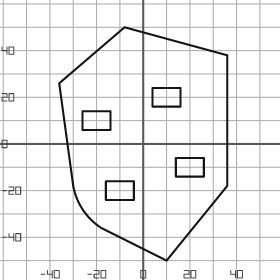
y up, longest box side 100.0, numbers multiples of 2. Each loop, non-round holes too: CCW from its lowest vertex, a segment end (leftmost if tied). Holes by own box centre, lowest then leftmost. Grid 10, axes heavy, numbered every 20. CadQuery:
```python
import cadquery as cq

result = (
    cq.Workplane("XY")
    .moveTo(10.0, -50.0)
    .lineTo(36.0, -18.0)
    .lineTo(36.0, 38.0)
    .lineTo(-8.0, 50.0)
    .lineTo(-36.0, 26.0)
    .lineTo(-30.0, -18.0)
    .threePointArc((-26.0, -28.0), (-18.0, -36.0))
    .close()
    .moveTo(-16.0, -24.0)
    .lineTo(-4.0, -24.0)
    .lineTo(-4.0, -16.0)
    .lineTo(-16.0, -16.0)
    .close()
    .moveTo(14.0, -14.0)
    .lineTo(26.0, -14.0)
    .lineTo(26.0, -6.0)
    .lineTo(14.0, -6.0)
    .close()
    .moveTo(-26.0, 6.0)
    .lineTo(-14.0, 6.0)
    .lineTo(-14.0, 14.0)
    .lineTo(-26.0, 14.0)
    .close()
    .moveTo(4.0, 16.0)
    .lineTo(16.0, 16.0)
    .lineTo(16.0, 24.0)
    .lineTo(4.0, 24.0)
    .close()
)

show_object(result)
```